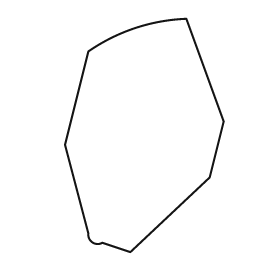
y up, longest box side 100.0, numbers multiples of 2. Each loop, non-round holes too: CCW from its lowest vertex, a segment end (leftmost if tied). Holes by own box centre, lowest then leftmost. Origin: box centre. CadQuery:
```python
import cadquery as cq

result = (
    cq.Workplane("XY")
    .moveTo(-6.0, -50.0)
    .lineTo(28.0, -18.0)
    .lineTo(34.0, 6.0)
    .lineTo(18.0, 50.0)
    .threePointArc((-4.0, 46.0), (-24.0, 36.0))
    .lineTo(-34.0, -4.0)
    .lineTo(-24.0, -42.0)
    .threePointArc((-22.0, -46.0), (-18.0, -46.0))
    .close()
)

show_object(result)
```